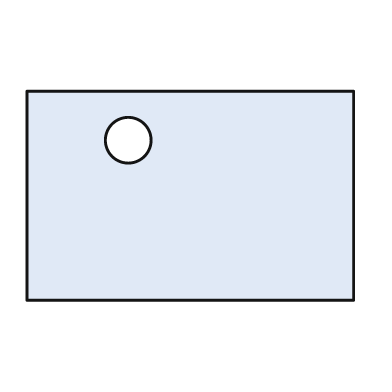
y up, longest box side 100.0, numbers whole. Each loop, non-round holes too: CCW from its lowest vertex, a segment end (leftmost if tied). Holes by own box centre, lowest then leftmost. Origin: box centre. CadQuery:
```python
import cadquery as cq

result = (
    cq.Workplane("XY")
    .moveTo(-50.0, -32.0)
    .lineTo(50.0, -32.0)
    .lineTo(50.0, 32.0)
    .lineTo(-50.0, 32.0)
    .close()
    .moveTo(-19.0, 17.0)
    .circle(7.0)
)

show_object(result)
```